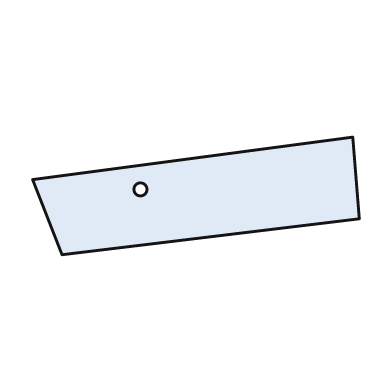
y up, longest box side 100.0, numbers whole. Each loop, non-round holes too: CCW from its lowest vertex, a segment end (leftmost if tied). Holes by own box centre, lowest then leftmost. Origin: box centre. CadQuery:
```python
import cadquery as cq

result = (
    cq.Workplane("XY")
    .moveTo(-41.0, -18.0)
    .lineTo(50.0, -7.0)
    .lineTo(48.0, 18.0)
    .lineTo(-50.0, 5.0)
    .close()
    .moveTo(-17.0, 2.0)
    .circle(2.0)
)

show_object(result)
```